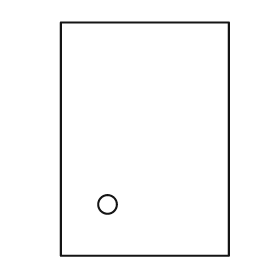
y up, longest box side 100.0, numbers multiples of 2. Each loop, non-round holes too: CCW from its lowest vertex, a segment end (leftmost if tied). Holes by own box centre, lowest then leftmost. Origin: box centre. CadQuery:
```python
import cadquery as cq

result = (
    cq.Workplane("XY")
    .moveTo(-36.0, -50.0)
    .lineTo(36.0, -50.0)
    .lineTo(36.0, 50.0)
    .lineTo(-36.0, 50.0)
    .close()
    .moveTo(-16.0, -28.0)
    .circle(4.0)
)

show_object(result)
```